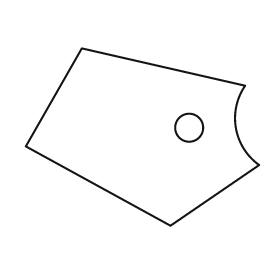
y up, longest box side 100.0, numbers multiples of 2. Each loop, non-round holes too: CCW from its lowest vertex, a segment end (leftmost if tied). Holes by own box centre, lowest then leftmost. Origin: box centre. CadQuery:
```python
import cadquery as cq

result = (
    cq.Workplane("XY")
    .moveTo(12.0, -38.0)
    .lineTo(50.0, -12.0)
    .threePointArc((40.0, 4.0), (44.0, 22.0))
    .lineTo(-26.0, 38.0)
    .lineTo(-50.0, -4.0)
    .close()
    .moveTo(20.0, 4.0)
    .circle(6.0)
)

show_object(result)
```